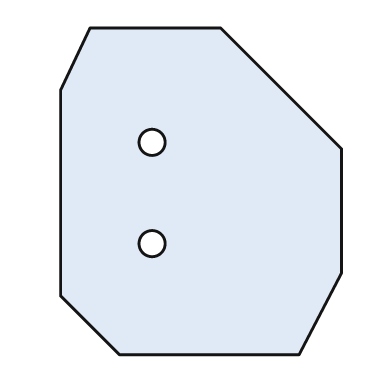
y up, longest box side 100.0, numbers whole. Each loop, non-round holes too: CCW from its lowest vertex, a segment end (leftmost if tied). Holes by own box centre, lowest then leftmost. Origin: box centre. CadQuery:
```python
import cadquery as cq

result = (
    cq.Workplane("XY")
    .moveTo(-25.0, -50.0)
    .lineTo(30.0, -50.0)
    .lineTo(43.0, -25.0)
    .lineTo(43.0, 13.0)
    .lineTo(6.0, 50.0)
    .lineTo(-34.0, 50.0)
    .lineTo(-43.0, 31.0)
    .lineTo(-43.0, -32.0)
    .close()
    .moveTo(-15.0, -16.0)
    .circle(4.0)
    .moveTo(-15.0, 15.0)
    .circle(4.0)
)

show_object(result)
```